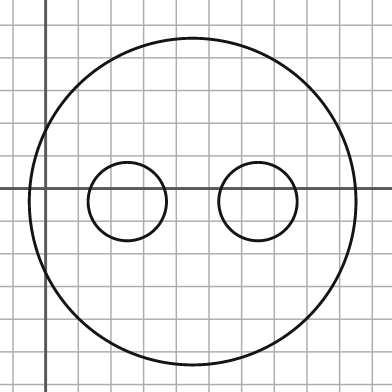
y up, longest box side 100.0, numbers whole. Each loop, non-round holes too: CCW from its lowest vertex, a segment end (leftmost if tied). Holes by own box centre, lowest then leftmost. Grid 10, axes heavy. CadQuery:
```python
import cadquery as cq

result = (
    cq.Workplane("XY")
    .moveTo(45.0, -4.0)
    .circle(50.0)
    .moveTo(25.0, -4.0)
    .circle(12.0)
    .moveTo(65.0, -4.0)
    .circle(12.0)
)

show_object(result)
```